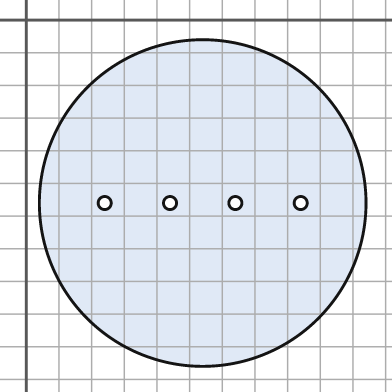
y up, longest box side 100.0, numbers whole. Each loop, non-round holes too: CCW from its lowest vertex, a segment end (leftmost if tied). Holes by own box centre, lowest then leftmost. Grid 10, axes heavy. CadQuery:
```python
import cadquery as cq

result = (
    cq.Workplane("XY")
    .moveTo(54.0, -56.0)
    .circle(50.0)
    .moveTo(24.0, -56.0)
    .circle(2.0)
    .moveTo(44.0, -56.0)
    .circle(2.0)
    .moveTo(64.0, -56.0)
    .circle(2.0)
    .moveTo(84.0, -56.0)
    .circle(2.0)
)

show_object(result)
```